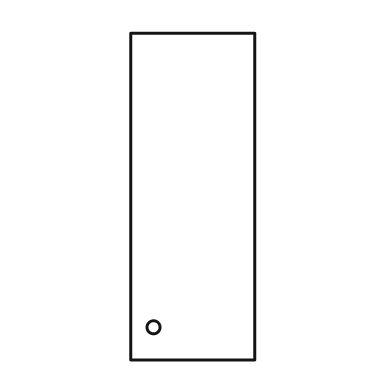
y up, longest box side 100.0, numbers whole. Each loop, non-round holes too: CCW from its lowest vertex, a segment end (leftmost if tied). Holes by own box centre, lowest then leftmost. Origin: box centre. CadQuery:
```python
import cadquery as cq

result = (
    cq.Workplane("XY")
    .moveTo(-19.0, -50.0)
    .lineTo(19.0, -50.0)
    .lineTo(19.0, 50.0)
    .lineTo(-19.0, 50.0)
    .close()
    .moveTo(-12.0, -40.0)
    .circle(2.0)
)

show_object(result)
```